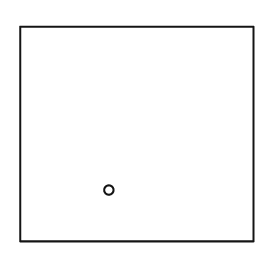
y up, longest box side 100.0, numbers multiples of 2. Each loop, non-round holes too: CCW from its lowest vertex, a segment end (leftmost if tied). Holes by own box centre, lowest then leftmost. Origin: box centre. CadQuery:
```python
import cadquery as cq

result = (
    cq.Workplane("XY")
    .moveTo(-50.0, -46.0)
    .lineTo(50.0, -46.0)
    .lineTo(50.0, 46.0)
    .lineTo(-50.0, 46.0)
    .close()
    .moveTo(-12.0, -24.0)
    .circle(2.0)
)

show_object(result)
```